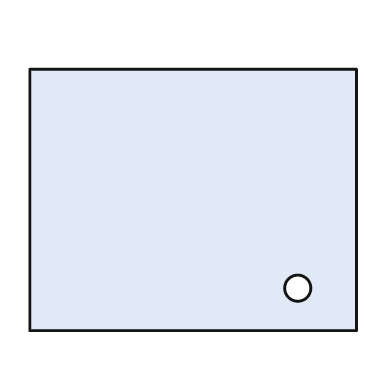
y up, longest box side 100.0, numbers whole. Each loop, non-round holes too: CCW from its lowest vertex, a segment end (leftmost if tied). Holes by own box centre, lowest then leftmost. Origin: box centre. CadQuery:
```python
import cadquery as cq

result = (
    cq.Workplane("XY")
    .moveTo(-50.0, -40.0)
    .lineTo(50.0, -40.0)
    .lineTo(50.0, 40.0)
    .lineTo(-50.0, 40.0)
    .close()
    .moveTo(32.0, -27.0)
    .circle(4.0)
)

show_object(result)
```